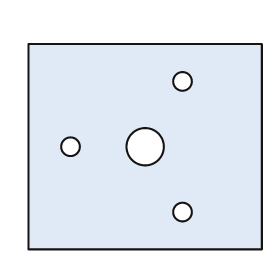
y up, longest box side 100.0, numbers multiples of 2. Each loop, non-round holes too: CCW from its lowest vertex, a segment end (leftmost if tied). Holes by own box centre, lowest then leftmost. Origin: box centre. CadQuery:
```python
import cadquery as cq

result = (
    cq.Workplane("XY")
    .moveTo(-50.0, -44.0)
    .lineTo(50.0, -44.0)
    .lineTo(50.0, 44.0)
    .lineTo(-50.0, 44.0)
    .close()
    .moveTo(16.0, -28.0)
    .circle(4.0)
    .moveTo(-32.0, 0.0)
    .circle(4.0)
    .moveTo(0.0, 0.0)
    .circle(8.0)
    .moveTo(16.0, 28.0)
    .circle(4.0)
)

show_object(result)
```